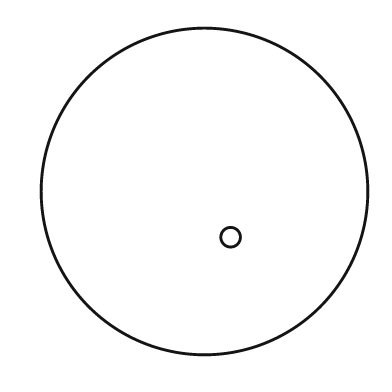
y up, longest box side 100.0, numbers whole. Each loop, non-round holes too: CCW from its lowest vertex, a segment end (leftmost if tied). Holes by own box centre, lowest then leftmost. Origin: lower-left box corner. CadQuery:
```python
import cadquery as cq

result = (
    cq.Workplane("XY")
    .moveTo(50.0, 50.0)
    .circle(50.0)
    .moveTo(58.0, 36.0)
    .circle(3.0)
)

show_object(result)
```